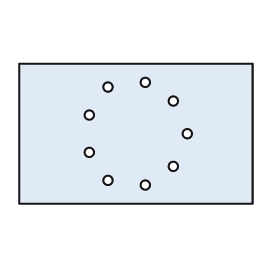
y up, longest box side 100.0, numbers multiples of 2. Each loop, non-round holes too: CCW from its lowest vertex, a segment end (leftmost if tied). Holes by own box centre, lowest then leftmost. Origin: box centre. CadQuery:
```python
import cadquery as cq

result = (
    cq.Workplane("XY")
    .moveTo(-50.0, -30.0)
    .lineTo(50.0, -30.0)
    .lineTo(50.0, 30.0)
    .lineTo(-50.0, 30.0)
    .close()
    .moveTo(4.0, -22.0)
    .circle(2.0)
    .moveTo(-12.0, -20.0)
    .circle(2.0)
    .moveTo(16.0, -14.0)
    .circle(2.0)
    .moveTo(-20.0, -8.0)
    .circle(2.0)
    .moveTo(22.0, 0.0)
    .circle(2.0)
    .moveTo(-20.0, 8.0)
    .circle(2.0)
    .moveTo(16.0, 14.0)
    .circle(2.0)
    .moveTo(-12.0, 20.0)
    .circle(2.0)
    .moveTo(4.0, 22.0)
    .circle(2.0)
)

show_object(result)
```